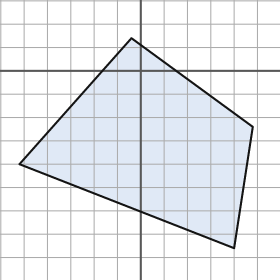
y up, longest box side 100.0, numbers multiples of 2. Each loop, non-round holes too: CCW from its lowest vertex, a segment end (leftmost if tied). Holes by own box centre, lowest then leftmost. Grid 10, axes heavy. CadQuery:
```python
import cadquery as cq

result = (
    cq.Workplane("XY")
    .moveTo(40.0, -76.0)
    .lineTo(48.0, -24.0)
    .lineTo(-4.0, 14.0)
    .lineTo(-52.0, -40.0)
    .close()
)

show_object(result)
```